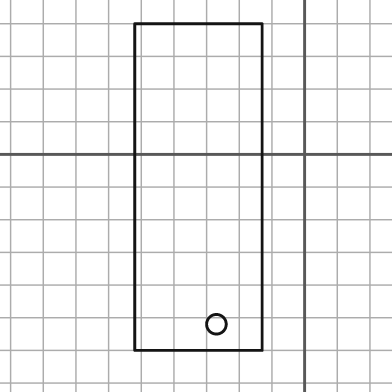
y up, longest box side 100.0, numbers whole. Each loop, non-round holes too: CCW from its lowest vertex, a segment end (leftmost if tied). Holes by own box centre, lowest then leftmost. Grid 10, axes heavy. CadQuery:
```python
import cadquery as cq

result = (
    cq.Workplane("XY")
    .moveTo(-52.0, -60.0)
    .lineTo(-13.0, -60.0)
    .lineTo(-13.0, 40.0)
    .lineTo(-52.0, 40.0)
    .close()
    .moveTo(-27.0, -52.0)
    .circle(3.0)
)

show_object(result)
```